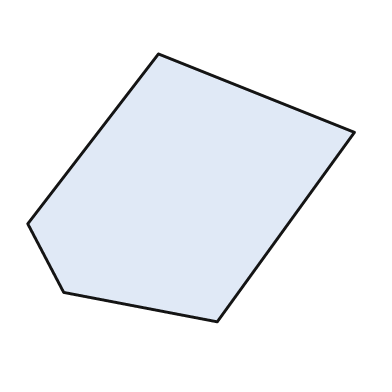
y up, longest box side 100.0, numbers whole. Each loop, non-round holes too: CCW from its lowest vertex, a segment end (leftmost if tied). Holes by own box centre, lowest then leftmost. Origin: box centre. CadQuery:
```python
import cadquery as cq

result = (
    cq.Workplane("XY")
    .moveTo(8.0, -41.0)
    .lineTo(50.0, 17.0)
    .lineTo(-10.0, 41.0)
    .lineTo(-50.0, -11.0)
    .lineTo(-39.0, -32.0)
    .close()
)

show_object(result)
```